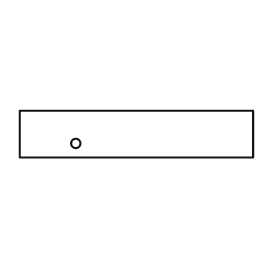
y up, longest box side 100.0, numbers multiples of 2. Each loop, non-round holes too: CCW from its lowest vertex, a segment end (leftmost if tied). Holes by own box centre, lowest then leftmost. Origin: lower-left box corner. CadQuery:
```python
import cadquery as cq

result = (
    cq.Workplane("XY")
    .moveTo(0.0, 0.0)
    .lineTo(100.0, 0.0)
    .lineTo(100.0, 20.0)
    .lineTo(0.0, 20.0)
    .close()
    .moveTo(24.0, 6.0)
    .circle(2.0)
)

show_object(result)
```